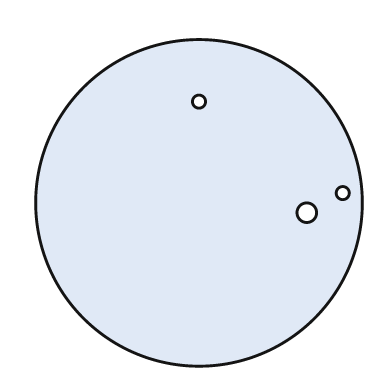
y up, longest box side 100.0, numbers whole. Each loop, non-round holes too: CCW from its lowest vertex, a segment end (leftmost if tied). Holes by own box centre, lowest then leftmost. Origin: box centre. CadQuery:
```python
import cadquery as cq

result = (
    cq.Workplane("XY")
    .moveTo(0.0, 0.0)
    .circle(50.0)
    .moveTo(33.0, -3.0)
    .circle(3.0)
    .moveTo(44.0, 3.0)
    .circle(2.0)
    .moveTo(0.0, 31.0)
    .circle(2.0)
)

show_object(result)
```